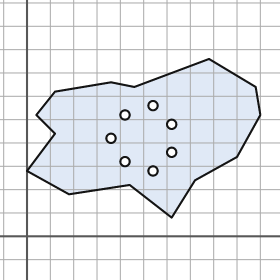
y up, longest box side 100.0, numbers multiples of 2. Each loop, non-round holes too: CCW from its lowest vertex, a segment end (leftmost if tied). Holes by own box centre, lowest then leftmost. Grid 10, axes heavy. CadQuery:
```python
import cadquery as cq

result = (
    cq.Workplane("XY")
    .moveTo(62.0, 8.0)
    .lineTo(72.0, 24.0)
    .lineTo(90.0, 34.0)
    .lineTo(100.0, 52.0)
    .lineTo(98.0, 64.0)
    .lineTo(78.0, 76.0)
    .lineTo(46.0, 64.0)
    .lineTo(36.0, 66.0)
    .lineTo(12.0, 62.0)
    .lineTo(4.0, 52.0)
    .lineTo(12.0, 44.0)
    .lineTo(0.0, 28.0)
    .lineTo(18.0, 18.0)
    .lineTo(44.0, 22.0)
    .close()
    .moveTo(54.0, 28.0)
    .circle(2.0)
    .moveTo(42.0, 32.0)
    .circle(2.0)
    .moveTo(62.0, 36.0)
    .circle(2.0)
    .moveTo(36.0, 42.0)
    .circle(2.0)
    .moveTo(62.0, 48.0)
    .circle(2.0)
    .moveTo(42.0, 52.0)
    .circle(2.0)
    .moveTo(54.0, 56.0)
    .circle(2.0)
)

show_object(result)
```